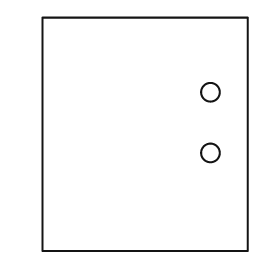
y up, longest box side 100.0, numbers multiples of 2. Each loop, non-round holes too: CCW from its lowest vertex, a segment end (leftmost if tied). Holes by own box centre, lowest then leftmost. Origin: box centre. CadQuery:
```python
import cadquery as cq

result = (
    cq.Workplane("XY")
    .moveTo(-44.0, -50.0)
    .lineTo(44.0, -50.0)
    .lineTo(44.0, 50.0)
    .lineTo(-44.0, 50.0)
    .close()
    .moveTo(28.0, -8.0)
    .circle(4.0)
    .moveTo(28.0, 18.0)
    .circle(4.0)
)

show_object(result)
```